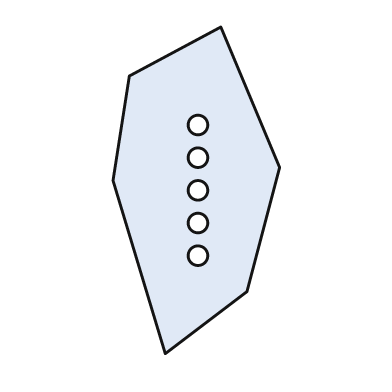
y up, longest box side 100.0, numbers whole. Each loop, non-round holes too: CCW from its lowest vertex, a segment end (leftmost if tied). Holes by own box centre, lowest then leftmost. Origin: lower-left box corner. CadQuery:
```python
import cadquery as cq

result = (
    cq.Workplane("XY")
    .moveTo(16.0, 0.0)
    .lineTo(41.0, 19.0)
    .lineTo(51.0, 57.0)
    .lineTo(33.0, 100.0)
    .lineTo(5.0, 85.0)
    .lineTo(0.0, 53.0)
    .close()
    .moveTo(26.0, 30.0)
    .circle(3.0)
    .moveTo(26.0, 40.0)
    .circle(3.0)
    .moveTo(26.0, 50.0)
    .circle(3.0)
    .moveTo(26.0, 60.0)
    .circle(3.0)
    .moveTo(26.0, 70.0)
    .circle(3.0)
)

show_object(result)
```